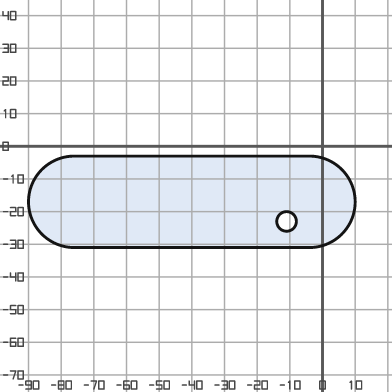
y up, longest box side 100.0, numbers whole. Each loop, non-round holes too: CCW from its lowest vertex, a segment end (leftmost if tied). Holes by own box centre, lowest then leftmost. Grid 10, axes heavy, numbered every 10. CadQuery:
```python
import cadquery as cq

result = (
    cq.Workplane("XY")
    .moveTo(-76.0, -31.0)
    .lineTo(-4.0, -31.0)
    .threePointArc((10.0, -17.0), (-4.0, -3.0))
    .lineTo(-76.0, -3.0)
    .threePointArc((-90.0, -17.0), (-76.0, -31.0))
    .close()
    .moveTo(-11.0, -23.0)
    .circle(3.0)
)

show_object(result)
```